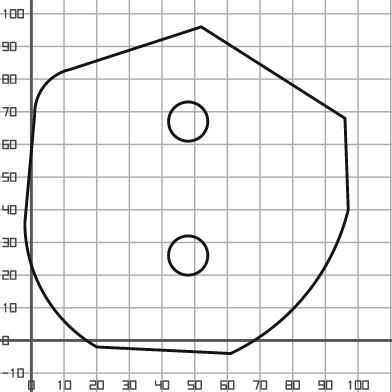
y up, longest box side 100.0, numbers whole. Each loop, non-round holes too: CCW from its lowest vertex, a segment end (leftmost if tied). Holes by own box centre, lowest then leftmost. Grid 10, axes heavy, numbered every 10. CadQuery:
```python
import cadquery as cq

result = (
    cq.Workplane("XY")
    .moveTo(61.0, -4.0)
    .threePointArc((84.0, 14.0), (97.0, 40.0))
    .lineTo(96.0, 68.0)
    .lineTo(52.0, 96.0)
    .lineTo(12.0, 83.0)
    .threePointArc((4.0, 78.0), (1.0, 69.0))
    .lineTo(-2.0, 36.0)
    .threePointArc((4.0, 14.0), (20.0, -2.0))
    .close()
    .moveTo(48.0, 26.0)
    .circle(6.0)
    .moveTo(48.0, 67.0)
    .circle(6.0)
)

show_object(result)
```